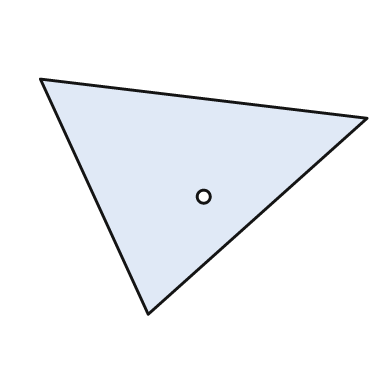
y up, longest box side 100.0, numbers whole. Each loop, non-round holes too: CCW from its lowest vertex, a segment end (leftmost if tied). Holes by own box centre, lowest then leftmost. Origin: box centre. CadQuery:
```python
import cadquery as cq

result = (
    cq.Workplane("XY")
    .moveTo(-17.0, -36.0)
    .lineTo(50.0, 24.0)
    .lineTo(-50.0, 36.0)
    .close()
    .moveTo(0.0, 0.0)
    .circle(2.0)
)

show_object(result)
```